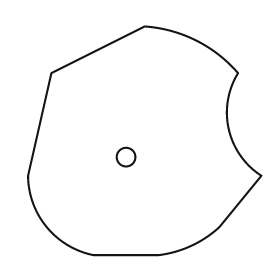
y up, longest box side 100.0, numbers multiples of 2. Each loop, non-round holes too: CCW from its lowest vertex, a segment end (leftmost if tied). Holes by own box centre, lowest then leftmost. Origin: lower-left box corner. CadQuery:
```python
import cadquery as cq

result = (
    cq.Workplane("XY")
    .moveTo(28.0, 0.0)
    .lineTo(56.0, 0.0)
    .threePointArc((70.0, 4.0), (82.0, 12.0))
    .lineTo(100.0, 34.0)
    .threePointArc((86.0, 54.0), (90.0, 78.0))
    .threePointArc((72.0, 92.0), (50.0, 98.0))
    .lineTo(10.0, 78.0)
    .lineTo(0.0, 34.0)
    .threePointArc((8.0, 12.0), (28.0, 0.0))
    .close()
    .moveTo(42.0, 42.0)
    .circle(4.0)
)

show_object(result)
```